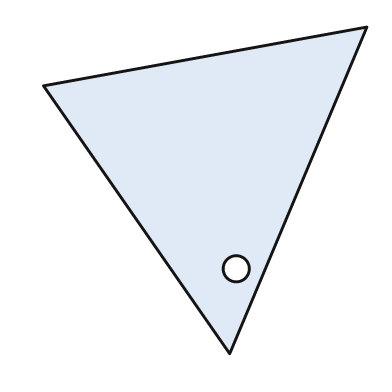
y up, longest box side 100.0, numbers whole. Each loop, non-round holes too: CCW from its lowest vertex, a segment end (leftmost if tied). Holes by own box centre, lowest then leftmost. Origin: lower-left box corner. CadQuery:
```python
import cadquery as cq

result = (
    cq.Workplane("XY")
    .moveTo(57.0, 0.0)
    .lineTo(99.0, 100.0)
    .lineTo(0.0, 82.0)
    .close()
    .moveTo(59.0, 26.0)
    .circle(4.0)
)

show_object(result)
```